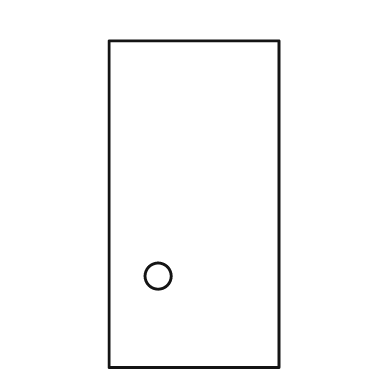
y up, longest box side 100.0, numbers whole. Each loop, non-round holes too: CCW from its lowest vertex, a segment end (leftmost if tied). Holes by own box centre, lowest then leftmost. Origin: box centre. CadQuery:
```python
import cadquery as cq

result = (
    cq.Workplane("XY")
    .moveTo(-26.0, -50.0)
    .lineTo(26.0, -50.0)
    .lineTo(26.0, 50.0)
    .lineTo(-26.0, 50.0)
    .close()
    .moveTo(-11.0, -22.0)
    .circle(4.0)
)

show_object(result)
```